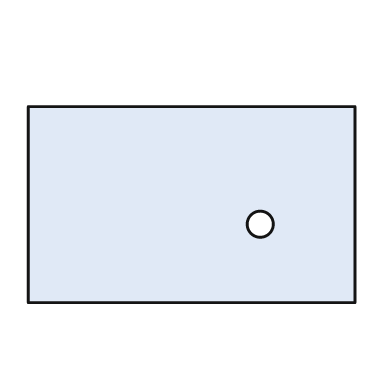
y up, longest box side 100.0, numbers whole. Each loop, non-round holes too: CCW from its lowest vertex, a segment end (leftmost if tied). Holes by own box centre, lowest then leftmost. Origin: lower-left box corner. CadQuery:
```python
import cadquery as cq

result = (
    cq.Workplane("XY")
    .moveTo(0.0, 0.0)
    .lineTo(100.0, 0.0)
    .lineTo(100.0, 60.0)
    .lineTo(0.0, 60.0)
    .close()
    .moveTo(71.0, 24.0)
    .circle(4.0)
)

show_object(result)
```